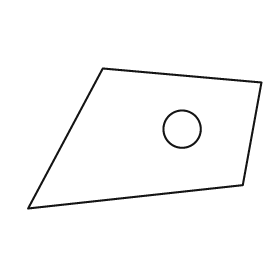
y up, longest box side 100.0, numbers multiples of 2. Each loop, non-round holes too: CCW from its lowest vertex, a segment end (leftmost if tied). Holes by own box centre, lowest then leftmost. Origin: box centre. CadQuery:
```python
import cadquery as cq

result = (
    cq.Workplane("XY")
    .moveTo(-50.0, -30.0)
    .lineTo(42.0, -20.0)
    .lineTo(50.0, 24.0)
    .lineTo(-18.0, 30.0)
    .close()
    .moveTo(16.0, 4.0)
    .circle(8.0)
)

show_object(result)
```